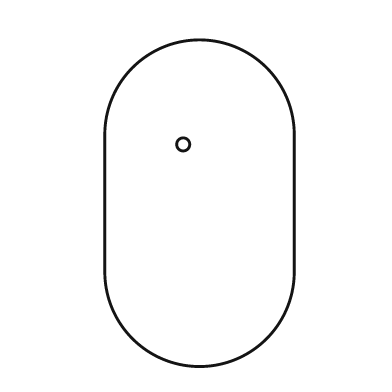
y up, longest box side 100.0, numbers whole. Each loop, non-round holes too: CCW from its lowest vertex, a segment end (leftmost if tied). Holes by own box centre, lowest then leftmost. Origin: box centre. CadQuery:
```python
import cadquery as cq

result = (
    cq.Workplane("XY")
    .moveTo(-29.0, -21.0)
    .threePointArc((0.0, -50.0), (29.0, -21.0))
    .lineTo(29.0, 21.0)
    .threePointArc((0.0, 50.0), (-29.0, 21.0))
    .close()
    .moveTo(-5.0, 18.0)
    .circle(2.0)
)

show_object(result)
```